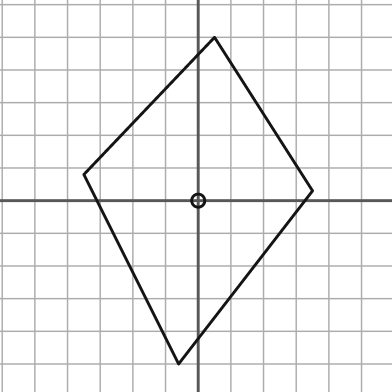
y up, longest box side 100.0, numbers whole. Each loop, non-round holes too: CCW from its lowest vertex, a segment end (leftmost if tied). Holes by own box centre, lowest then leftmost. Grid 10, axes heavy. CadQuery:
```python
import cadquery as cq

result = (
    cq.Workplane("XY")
    .moveTo(-6.0, -50.0)
    .lineTo(35.0, 3.0)
    .lineTo(5.0, 50.0)
    .lineTo(-35.0, 8.0)
    .close()
    .moveTo(0.0, 0.0)
    .circle(2.0)
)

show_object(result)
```